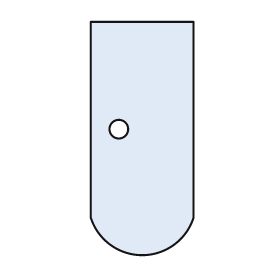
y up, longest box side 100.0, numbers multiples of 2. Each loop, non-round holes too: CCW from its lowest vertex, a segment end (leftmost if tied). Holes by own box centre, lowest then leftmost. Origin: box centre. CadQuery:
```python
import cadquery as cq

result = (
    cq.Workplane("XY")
    .moveTo(-22.0, -34.0)
    .threePointArc((0.0, -50.0), (22.0, -34.0))
    .lineTo(22.0, 50.0)
    .lineTo(-22.0, 50.0)
    .close()
    .moveTo(-10.0, 4.0)
    .circle(4.0)
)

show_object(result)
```